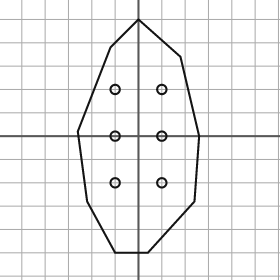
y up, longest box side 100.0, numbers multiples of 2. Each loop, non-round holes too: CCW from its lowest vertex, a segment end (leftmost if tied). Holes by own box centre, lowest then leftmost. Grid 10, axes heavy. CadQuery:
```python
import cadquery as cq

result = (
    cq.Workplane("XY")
    .moveTo(-10.0, -50.0)
    .lineTo(4.0, -50.0)
    .lineTo(24.0, -28.0)
    .lineTo(26.0, 0.0)
    .lineTo(18.0, 34.0)
    .lineTo(0.0, 50.0)
    .lineTo(-12.0, 38.0)
    .lineTo(-26.0, 2.0)
    .lineTo(-22.0, -28.0)
    .close()
    .moveTo(-10.0, -20.0)
    .circle(2.0)
    .moveTo(10.0, -20.0)
    .circle(2.0)
    .moveTo(-10.0, 0.0)
    .circle(2.0)
    .moveTo(10.0, 0.0)
    .circle(2.0)
    .moveTo(-10.0, 20.0)
    .circle(2.0)
    .moveTo(10.0, 20.0)
    .circle(2.0)
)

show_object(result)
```